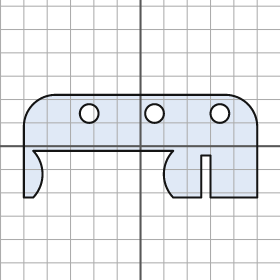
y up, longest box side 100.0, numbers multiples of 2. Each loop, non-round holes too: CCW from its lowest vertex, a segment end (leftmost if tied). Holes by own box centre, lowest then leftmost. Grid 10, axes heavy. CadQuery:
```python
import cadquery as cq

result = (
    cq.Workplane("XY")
    .moveTo(-50.0, -22.0)
    .lineTo(-46.0, -22.0)
    .threePointArc((-42.0, -12.0), (-46.0, -2.0))
    .lineTo(14.0, -2.0)
    .threePointArc((10.0, -12.0), (14.0, -22.0))
    .lineTo(26.0, -22.0)
    .lineTo(26.0, -4.0)
    .lineTo(30.0, -4.0)
    .lineTo(30.0, -22.0)
    .lineTo(50.0, -22.0)
    .lineTo(50.0, 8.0)
    .threePointArc((46.0, 18.0), (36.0, 22.0))
    .lineTo(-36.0, 22.0)
    .threePointArc((-46.0, 18.0), (-50.0, 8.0))
    .close()
    .moveTo(-22.0, 14.0)
    .circle(4.0)
    .moveTo(6.0, 14.0)
    .circle(4.0)
    .moveTo(34.0, 14.0)
    .circle(4.0)
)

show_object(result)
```